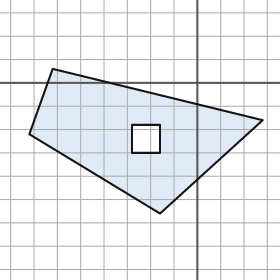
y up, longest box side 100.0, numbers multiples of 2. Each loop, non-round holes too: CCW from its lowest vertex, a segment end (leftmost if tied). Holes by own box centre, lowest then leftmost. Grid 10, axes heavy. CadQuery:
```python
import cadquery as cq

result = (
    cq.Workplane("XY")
    .moveTo(-16.0, -56.0)
    .lineTo(28.0, -16.0)
    .lineTo(-62.0, 6.0)
    .lineTo(-72.0, -22.0)
    .close()
    .moveTo(-28.0, -30.0)
    .lineTo(-16.0, -30.0)
    .lineTo(-16.0, -18.0)
    .lineTo(-28.0, -18.0)
    .close()
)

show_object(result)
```